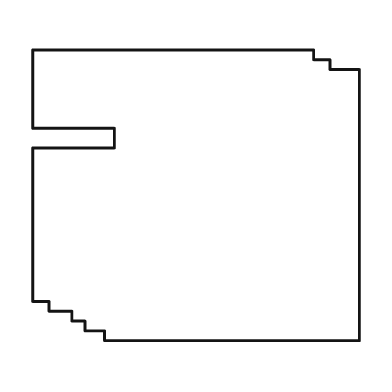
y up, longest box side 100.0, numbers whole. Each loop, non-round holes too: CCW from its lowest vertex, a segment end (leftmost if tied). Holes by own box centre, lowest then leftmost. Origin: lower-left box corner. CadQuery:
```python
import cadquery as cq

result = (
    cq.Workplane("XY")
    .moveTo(22.0, 0.0)
    .lineTo(100.0, 0.0)
    .lineTo(100.0, 83.0)
    .lineTo(91.0, 83.0)
    .lineTo(91.0, 86.0)
    .lineTo(86.0, 86.0)
    .lineTo(86.0, 89.0)
    .lineTo(0.0, 89.0)
    .lineTo(0.0, 65.0)
    .lineTo(25.0, 65.0)
    .lineTo(25.0, 59.0)
    .lineTo(0.0, 59.0)
    .lineTo(0.0, 12.0)
    .lineTo(5.0, 12.0)
    .lineTo(5.0, 9.0)
    .lineTo(12.0, 9.0)
    .lineTo(12.0, 6.0)
    .lineTo(16.0, 6.0)
    .lineTo(16.0, 3.0)
    .lineTo(22.0, 3.0)
    .close()
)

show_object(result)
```